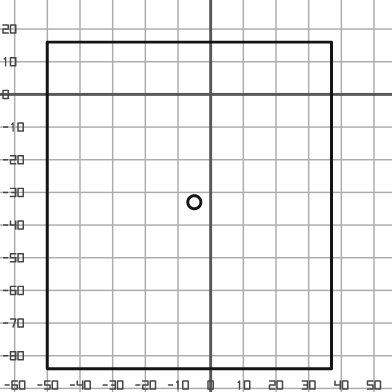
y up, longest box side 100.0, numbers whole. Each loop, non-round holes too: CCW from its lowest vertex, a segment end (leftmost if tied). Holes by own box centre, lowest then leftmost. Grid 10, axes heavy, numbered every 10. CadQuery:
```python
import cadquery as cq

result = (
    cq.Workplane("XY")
    .moveTo(-50.0, -84.0)
    .lineTo(37.0, -84.0)
    .lineTo(37.0, 16.0)
    .lineTo(-50.0, 16.0)
    .close()
    .moveTo(-5.0, -33.0)
    .circle(2.0)
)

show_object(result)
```